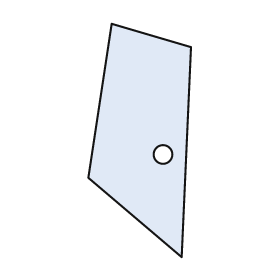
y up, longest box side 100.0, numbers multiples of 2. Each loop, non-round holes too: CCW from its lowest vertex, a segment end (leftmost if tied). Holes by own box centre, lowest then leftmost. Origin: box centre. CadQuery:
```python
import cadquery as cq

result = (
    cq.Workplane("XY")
    .moveTo(18.0, -50.0)
    .lineTo(22.0, 40.0)
    .lineTo(-12.0, 50.0)
    .lineTo(-22.0, -16.0)
    .close()
    .moveTo(10.0, -6.0)
    .circle(4.0)
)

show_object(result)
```